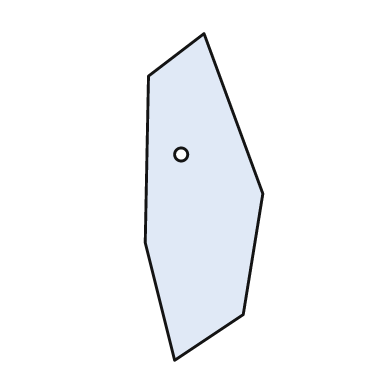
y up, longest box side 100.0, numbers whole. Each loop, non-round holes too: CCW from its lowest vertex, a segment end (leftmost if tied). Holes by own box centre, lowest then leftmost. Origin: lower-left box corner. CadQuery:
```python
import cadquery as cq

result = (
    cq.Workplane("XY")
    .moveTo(9.0, 0.0)
    .lineTo(30.0, 14.0)
    .lineTo(36.0, 51.0)
    .lineTo(18.0, 100.0)
    .lineTo(1.0, 87.0)
    .lineTo(0.0, 36.0)
    .close()
    .moveTo(11.0, 63.0)
    .circle(2.0)
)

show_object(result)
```